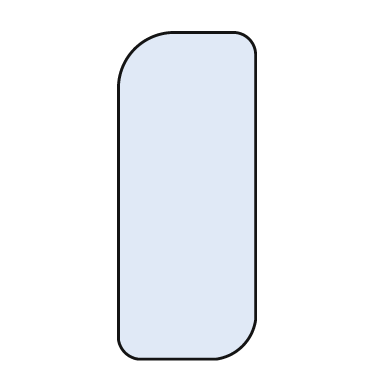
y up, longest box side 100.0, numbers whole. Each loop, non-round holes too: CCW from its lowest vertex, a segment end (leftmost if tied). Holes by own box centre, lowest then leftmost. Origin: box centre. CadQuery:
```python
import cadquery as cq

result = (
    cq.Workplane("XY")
    .moveTo(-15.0, -50.0)
    .lineTo(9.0, -50.0)
    .threePointArc((17.0, -46.0), (21.0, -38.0))
    .lineTo(21.0, 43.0)
    .threePointArc((19.0, 48.0), (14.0, 50.0))
    .lineTo(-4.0, 50.0)
    .threePointArc((-16.0, 45.0), (-21.0, 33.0))
    .lineTo(-21.0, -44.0)
    .threePointArc((-19.0, -48.0), (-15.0, -50.0))
    .close()
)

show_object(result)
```